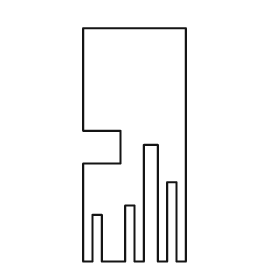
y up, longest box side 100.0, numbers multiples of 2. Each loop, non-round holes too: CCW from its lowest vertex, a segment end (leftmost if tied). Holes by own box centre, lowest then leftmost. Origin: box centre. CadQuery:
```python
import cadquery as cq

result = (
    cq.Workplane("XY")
    .moveTo(-22.0, -50.0)
    .lineTo(-18.0, -50.0)
    .lineTo(-18.0, -30.0)
    .lineTo(-14.0, -30.0)
    .lineTo(-14.0, -50.0)
    .lineTo(-4.0, -50.0)
    .lineTo(-4.0, -26.0)
    .lineTo(0.0, -26.0)
    .lineTo(0.0, -50.0)
    .lineTo(4.0, -50.0)
    .lineTo(4.0, 0.0)
    .lineTo(10.0, 0.0)
    .lineTo(10.0, -50.0)
    .lineTo(14.0, -50.0)
    .lineTo(14.0, -16.0)
    .lineTo(18.0, -16.0)
    .lineTo(18.0, -50.0)
    .lineTo(22.0, -50.0)
    .lineTo(22.0, 50.0)
    .lineTo(-22.0, 50.0)
    .lineTo(-22.0, 6.0)
    .lineTo(-6.0, 6.0)
    .lineTo(-6.0, -8.0)
    .lineTo(-22.0, -8.0)
    .close()
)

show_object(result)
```